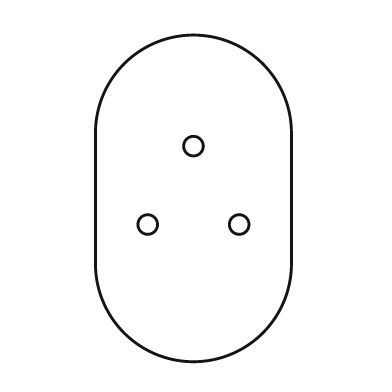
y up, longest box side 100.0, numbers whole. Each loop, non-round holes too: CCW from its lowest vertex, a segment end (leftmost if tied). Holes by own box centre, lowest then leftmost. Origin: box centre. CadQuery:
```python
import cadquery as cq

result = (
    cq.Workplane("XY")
    .moveTo(-30.0, -20.0)
    .threePointArc((0.0, -50.0), (30.0, -20.0))
    .lineTo(30.0, 20.0)
    .threePointArc((0.0, 50.0), (-30.0, 20.0))
    .close()
    .moveTo(-14.0, -8.0)
    .circle(3.0)
    .moveTo(14.0, -8.0)
    .circle(3.0)
    .moveTo(0.0, 16.0)
    .circle(3.0)
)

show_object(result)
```